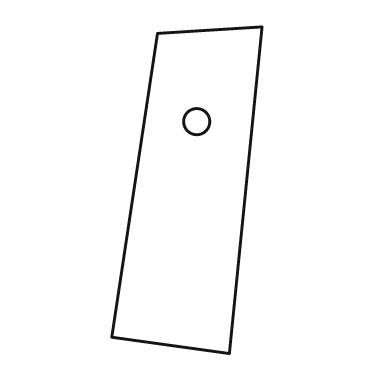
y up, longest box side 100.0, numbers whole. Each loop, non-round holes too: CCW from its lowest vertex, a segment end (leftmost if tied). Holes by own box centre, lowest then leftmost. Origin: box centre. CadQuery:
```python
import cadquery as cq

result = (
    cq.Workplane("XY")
    .moveTo(13.0, -50.0)
    .lineTo(23.0, 50.0)
    .lineTo(-9.0, 48.0)
    .lineTo(-23.0, -45.0)
    .close()
    .moveTo(3.0, 21.0)
    .circle(4.0)
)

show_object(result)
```